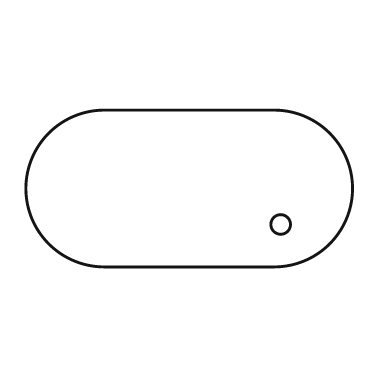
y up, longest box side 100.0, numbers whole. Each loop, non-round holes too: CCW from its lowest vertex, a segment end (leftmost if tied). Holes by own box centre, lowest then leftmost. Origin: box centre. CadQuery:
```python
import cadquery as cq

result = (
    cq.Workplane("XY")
    .moveTo(-26.0, -24.0)
    .lineTo(26.0, -24.0)
    .threePointArc((50.0, 0.0), (26.0, 24.0))
    .lineTo(-26.0, 24.0)
    .threePointArc((-50.0, 0.0), (-26.0, -24.0))
    .close()
    .moveTo(28.0, -11.0)
    .circle(3.0)
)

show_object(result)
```